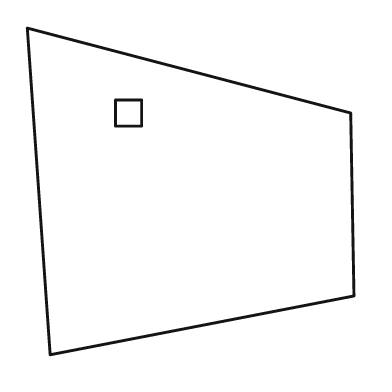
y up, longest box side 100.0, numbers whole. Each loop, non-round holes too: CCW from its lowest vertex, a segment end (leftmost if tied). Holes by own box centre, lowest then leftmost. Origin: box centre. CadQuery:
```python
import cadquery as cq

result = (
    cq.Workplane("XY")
    .moveTo(-43.0, -50.0)
    .lineTo(50.0, -32.0)
    .lineTo(49.0, 24.0)
    .lineTo(-50.0, 50.0)
    .close()
    .moveTo(-23.0, 20.0)
    .lineTo(-15.0, 20.0)
    .lineTo(-15.0, 28.0)
    .lineTo(-23.0, 28.0)
    .close()
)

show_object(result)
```